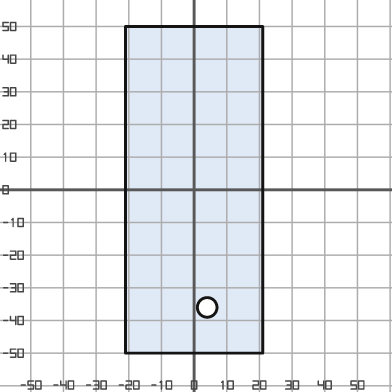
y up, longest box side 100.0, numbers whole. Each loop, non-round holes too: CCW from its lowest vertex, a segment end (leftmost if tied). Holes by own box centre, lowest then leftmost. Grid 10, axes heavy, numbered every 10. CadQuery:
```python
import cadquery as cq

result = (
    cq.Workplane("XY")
    .moveTo(-21.0, -50.0)
    .lineTo(21.0, -50.0)
    .lineTo(21.0, 50.0)
    .lineTo(-21.0, 50.0)
    .close()
    .moveTo(4.0, -36.0)
    .circle(3.0)
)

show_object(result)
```